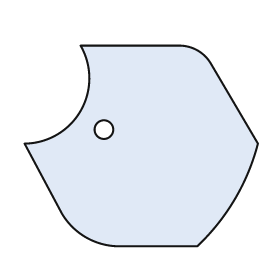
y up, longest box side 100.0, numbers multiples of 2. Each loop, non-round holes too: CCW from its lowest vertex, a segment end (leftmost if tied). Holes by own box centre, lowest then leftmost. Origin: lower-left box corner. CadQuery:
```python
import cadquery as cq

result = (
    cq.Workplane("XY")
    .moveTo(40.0, 0.0)
    .lineTo(74.0, 0.0)
    .threePointArc((90.0, 20.0), (100.0, 44.0))
    .lineTo(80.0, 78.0)
    .threePointArc((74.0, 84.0), (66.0, 86.0))
    .lineTo(24.0, 86.0)
    .threePointArc((24.0, 58.0), (0.0, 44.0))
    .lineTo(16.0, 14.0)
    .threePointArc((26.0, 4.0), (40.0, 0.0))
    .close()
    .moveTo(34.0, 50.0)
    .circle(4.0)
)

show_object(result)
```